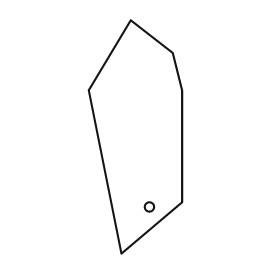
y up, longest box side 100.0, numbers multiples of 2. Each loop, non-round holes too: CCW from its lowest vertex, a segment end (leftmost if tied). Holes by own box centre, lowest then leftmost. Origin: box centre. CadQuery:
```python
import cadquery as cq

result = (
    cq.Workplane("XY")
    .moveTo(-6.0, -50.0)
    .lineTo(20.0, -28.0)
    .lineTo(20.0, 20.0)
    .lineTo(16.0, 36.0)
    .lineTo(-2.0, 50.0)
    .lineTo(-20.0, 20.0)
    .close()
    .moveTo(6.0, -30.0)
    .circle(2.0)
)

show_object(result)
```